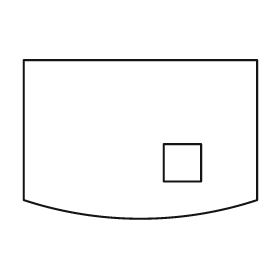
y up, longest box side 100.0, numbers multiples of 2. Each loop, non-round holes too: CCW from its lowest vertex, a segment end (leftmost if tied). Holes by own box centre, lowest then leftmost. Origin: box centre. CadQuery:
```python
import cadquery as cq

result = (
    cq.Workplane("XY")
    .moveTo(-50.0, -26.0)
    .threePointArc((0.0, -34.0), (50.0, -26.0))
    .lineTo(50.0, 34.0)
    .lineTo(-50.0, 34.0)
    .close()
    .moveTo(10.0, -18.0)
    .lineTo(26.0, -18.0)
    .lineTo(26.0, -2.0)
    .lineTo(10.0, -2.0)
    .close()
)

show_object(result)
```